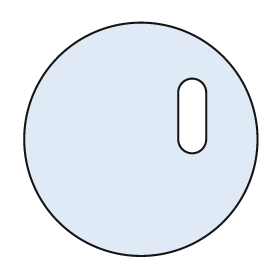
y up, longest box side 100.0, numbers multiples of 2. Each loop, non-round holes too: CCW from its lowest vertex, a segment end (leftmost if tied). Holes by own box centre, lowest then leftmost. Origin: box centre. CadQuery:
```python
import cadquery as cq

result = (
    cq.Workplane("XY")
    .moveTo(0.0, 0.0)
    .circle(50.0)
    .moveTo(16.0, 0.0)
    .threePointArc((22.0, -6.0), (28.0, 0.0))
    .lineTo(28.0, 20.0)
    .threePointArc((22.0, 26.0), (16.0, 20.0))
    .close()
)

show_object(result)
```